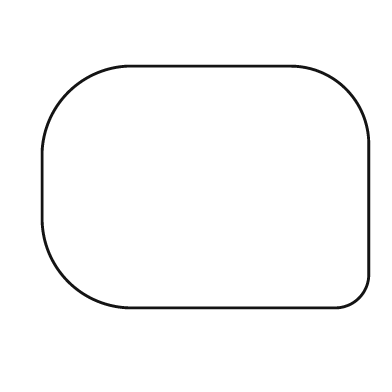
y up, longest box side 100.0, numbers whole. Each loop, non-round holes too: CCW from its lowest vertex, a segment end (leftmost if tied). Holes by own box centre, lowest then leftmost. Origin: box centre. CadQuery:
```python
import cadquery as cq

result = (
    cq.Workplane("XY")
    .moveTo(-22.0, -37.0)
    .lineTo(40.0, -37.0)
    .threePointArc((47.0, -34.0), (50.0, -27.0))
    .lineTo(50.0, 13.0)
    .threePointArc((43.0, 30.0), (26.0, 37.0))
    .lineTo(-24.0, 37.0)
    .threePointArc((-42.0, 29.0), (-50.0, 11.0))
    .lineTo(-50.0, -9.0)
    .threePointArc((-42.0, -29.0), (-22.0, -37.0))
    .close()
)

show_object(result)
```